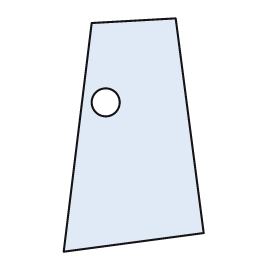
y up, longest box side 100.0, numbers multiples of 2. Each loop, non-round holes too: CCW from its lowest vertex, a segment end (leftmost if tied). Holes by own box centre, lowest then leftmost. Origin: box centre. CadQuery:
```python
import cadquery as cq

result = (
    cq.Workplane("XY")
    .moveTo(-30.0, -50.0)
    .lineTo(30.0, -42.0)
    .lineTo(18.0, 50.0)
    .lineTo(-18.0, 48.0)
    .close()
    .moveTo(-12.0, 14.0)
    .circle(6.0)
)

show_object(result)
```